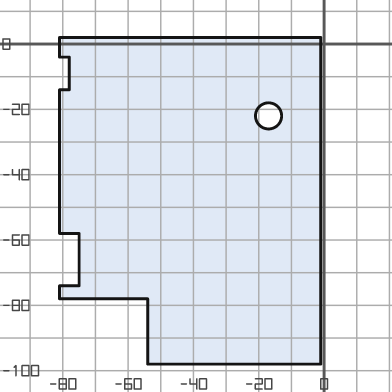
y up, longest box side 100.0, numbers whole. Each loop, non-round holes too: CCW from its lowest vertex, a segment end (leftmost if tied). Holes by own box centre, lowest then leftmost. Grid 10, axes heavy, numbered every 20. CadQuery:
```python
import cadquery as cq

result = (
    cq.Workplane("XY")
    .moveTo(-54.0, -98.0)
    .lineTo(-1.0, -98.0)
    .lineTo(-1.0, 2.0)
    .lineTo(-81.0, 2.0)
    .lineTo(-81.0, -4.0)
    .lineTo(-78.0, -4.0)
    .lineTo(-78.0, -14.0)
    .lineTo(-81.0, -14.0)
    .lineTo(-81.0, -58.0)
    .lineTo(-75.0, -58.0)
    .lineTo(-75.0, -74.0)
    .lineTo(-81.0, -74.0)
    .lineTo(-81.0, -78.0)
    .lineTo(-54.0, -78.0)
    .close()
    .moveTo(-17.0, -22.0)
    .circle(4.0)
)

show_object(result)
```